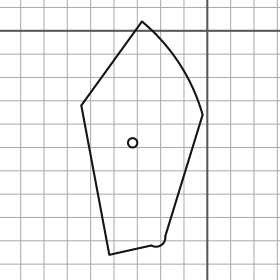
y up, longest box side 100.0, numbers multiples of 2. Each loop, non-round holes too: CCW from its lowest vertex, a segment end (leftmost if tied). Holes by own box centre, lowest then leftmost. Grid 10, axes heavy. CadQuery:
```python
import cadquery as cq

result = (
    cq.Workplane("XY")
    .moveTo(-42.0, -96.0)
    .lineTo(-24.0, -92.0)
    .threePointArc((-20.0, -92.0), (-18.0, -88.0))
    .lineTo(-2.0, -36.0)
    .threePointArc((-12.0, -14.0), (-28.0, 4.0))
    .lineTo(-54.0, -32.0)
    .close()
    .moveTo(-32.0, -48.0)
    .circle(2.0)
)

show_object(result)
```